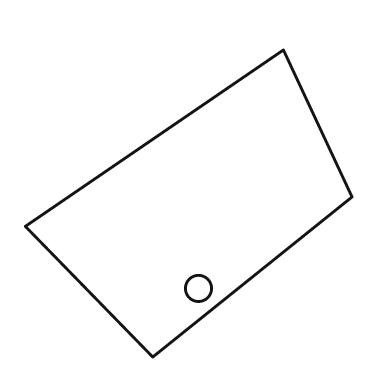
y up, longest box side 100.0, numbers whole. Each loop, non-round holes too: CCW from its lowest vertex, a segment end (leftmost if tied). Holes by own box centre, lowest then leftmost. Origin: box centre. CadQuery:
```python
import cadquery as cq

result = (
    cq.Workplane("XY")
    .moveTo(-11.0, -47.0)
    .lineTo(50.0, 2.0)
    .lineTo(29.0, 47.0)
    .lineTo(-50.0, -7.0)
    .close()
    .moveTo(3.0, -26.0)
    .circle(4.0)
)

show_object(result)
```